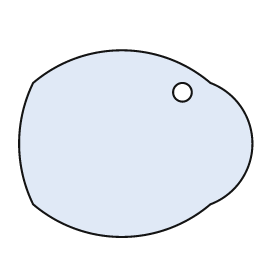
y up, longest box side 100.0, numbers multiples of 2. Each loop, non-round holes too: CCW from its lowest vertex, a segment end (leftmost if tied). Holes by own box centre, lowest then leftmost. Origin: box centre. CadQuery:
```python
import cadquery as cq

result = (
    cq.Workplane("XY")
    .moveTo(-44.0, -26.0)
    .threePointArc((-6.0, -40.0), (32.0, -26.0))
    .threePointArc((50.0, 0.0), (32.0, 26.0))
    .threePointArc((-6.0, 40.0), (-44.0, 26.0))
    .threePointArc((-50.0, 0.0), (-44.0, -26.0))
    .close()
    .moveTo(20.0, 22.0)
    .circle(4.0)
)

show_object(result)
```